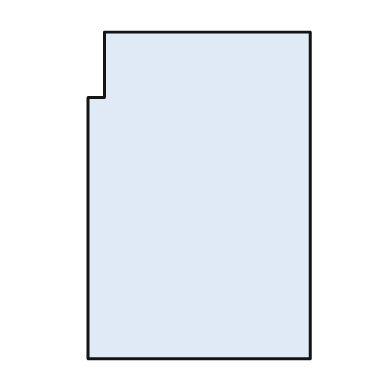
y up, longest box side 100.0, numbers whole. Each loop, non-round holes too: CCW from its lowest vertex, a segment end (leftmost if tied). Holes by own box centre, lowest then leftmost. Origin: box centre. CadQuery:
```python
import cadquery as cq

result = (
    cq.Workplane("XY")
    .moveTo(-34.0, -50.0)
    .lineTo(34.0, -50.0)
    .lineTo(34.0, 50.0)
    .lineTo(-29.0, 50.0)
    .lineTo(-29.0, 30.0)
    .lineTo(-34.0, 30.0)
    .close()
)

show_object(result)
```